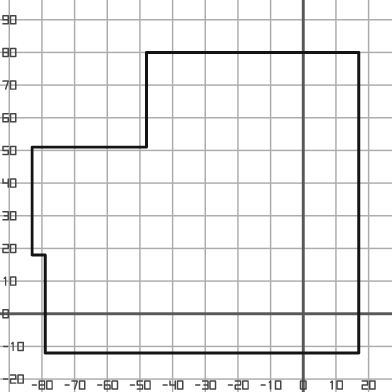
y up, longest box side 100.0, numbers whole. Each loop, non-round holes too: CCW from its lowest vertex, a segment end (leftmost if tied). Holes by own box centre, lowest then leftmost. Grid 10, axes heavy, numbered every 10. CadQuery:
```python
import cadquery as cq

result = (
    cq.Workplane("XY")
    .moveTo(-79.0, -12.0)
    .lineTo(17.0, -12.0)
    .lineTo(17.0, 80.0)
    .lineTo(-48.0, 80.0)
    .lineTo(-48.0, 51.0)
    .lineTo(-83.0, 51.0)
    .lineTo(-83.0, 18.0)
    .lineTo(-79.0, 18.0)
    .close()
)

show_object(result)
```